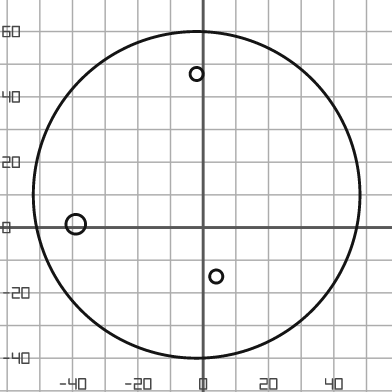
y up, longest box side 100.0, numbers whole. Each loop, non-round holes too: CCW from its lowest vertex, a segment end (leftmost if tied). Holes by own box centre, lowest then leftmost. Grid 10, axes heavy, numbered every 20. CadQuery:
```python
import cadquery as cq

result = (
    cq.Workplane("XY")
    .moveTo(-2.0, 10.0)
    .circle(50.0)
    .moveTo(4.0, -15.0)
    .circle(2.0)
    .moveTo(-39.0, 1.0)
    .circle(3.0)
    .moveTo(-2.0, 47.0)
    .circle(2.0)
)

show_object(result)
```